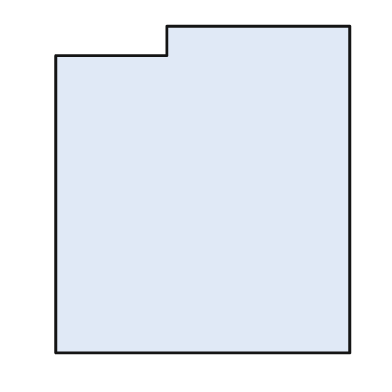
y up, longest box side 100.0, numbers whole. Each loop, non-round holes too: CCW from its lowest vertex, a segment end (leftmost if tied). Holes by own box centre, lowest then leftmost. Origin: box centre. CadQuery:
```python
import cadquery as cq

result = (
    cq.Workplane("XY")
    .moveTo(-45.0, -50.0)
    .lineTo(45.0, -50.0)
    .lineTo(45.0, 50.0)
    .lineTo(-11.0, 50.0)
    .lineTo(-11.0, 41.0)
    .lineTo(-45.0, 41.0)
    .close()
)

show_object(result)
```